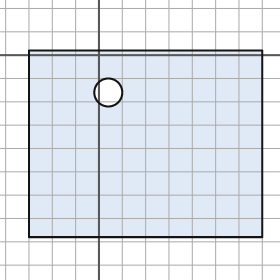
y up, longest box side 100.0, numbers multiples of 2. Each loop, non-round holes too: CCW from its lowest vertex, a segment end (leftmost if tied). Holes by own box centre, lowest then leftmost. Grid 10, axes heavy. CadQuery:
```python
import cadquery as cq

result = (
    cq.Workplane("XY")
    .moveTo(-30.0, -78.0)
    .lineTo(70.0, -78.0)
    .lineTo(70.0, 2.0)
    .lineTo(-30.0, 2.0)
    .close()
    .moveTo(4.0, -16.0)
    .circle(6.0)
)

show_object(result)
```